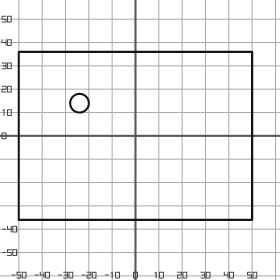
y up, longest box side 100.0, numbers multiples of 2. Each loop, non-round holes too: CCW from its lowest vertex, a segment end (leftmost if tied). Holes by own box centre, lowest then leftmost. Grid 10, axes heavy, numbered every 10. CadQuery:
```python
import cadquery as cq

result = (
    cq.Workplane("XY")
    .moveTo(-50.0, -36.0)
    .lineTo(50.0, -36.0)
    .lineTo(50.0, 36.0)
    .lineTo(-50.0, 36.0)
    .close()
    .moveTo(-24.0, 14.0)
    .circle(4.0)
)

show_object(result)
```